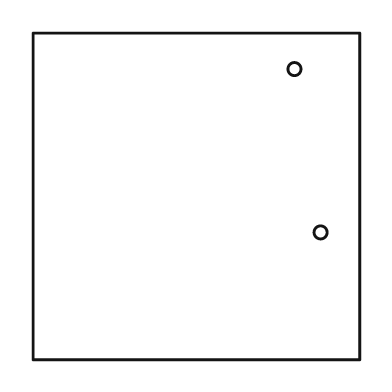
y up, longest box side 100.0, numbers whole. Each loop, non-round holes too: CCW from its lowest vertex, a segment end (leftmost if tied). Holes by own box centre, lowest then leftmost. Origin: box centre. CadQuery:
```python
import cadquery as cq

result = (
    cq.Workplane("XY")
    .moveTo(-50.0, -50.0)
    .lineTo(50.0, -50.0)
    .lineTo(50.0, 50.0)
    .lineTo(-50.0, 50.0)
    .close()
    .moveTo(38.0, -11.0)
    .circle(2.0)
    .moveTo(30.0, 39.0)
    .circle(2.0)
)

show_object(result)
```